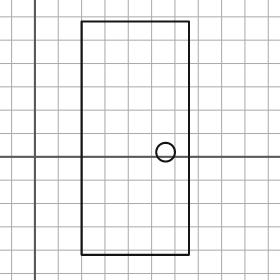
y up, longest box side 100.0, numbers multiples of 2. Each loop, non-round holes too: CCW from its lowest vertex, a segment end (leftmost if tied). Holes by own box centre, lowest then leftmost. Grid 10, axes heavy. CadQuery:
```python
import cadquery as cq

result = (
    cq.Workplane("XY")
    .moveTo(20.0, -42.0)
    .lineTo(66.0, -42.0)
    .lineTo(66.0, 58.0)
    .lineTo(20.0, 58.0)
    .close()
    .moveTo(56.0, 2.0)
    .circle(4.0)
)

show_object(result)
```